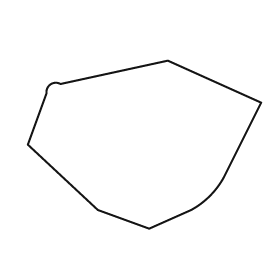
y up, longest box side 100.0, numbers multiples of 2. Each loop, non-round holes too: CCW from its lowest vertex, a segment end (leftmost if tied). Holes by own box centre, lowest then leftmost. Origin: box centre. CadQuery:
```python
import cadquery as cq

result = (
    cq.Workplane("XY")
    .moveTo(2.0, -36.0)
    .lineTo(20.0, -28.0)
    .threePointArc((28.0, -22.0), (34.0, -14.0))
    .lineTo(50.0, 18.0)
    .lineTo(10.0, 36.0)
    .lineTo(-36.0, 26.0)
    .threePointArc((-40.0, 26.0), (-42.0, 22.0))
    .lineTo(-50.0, 0.0)
    .lineTo(-20.0, -28.0)
    .close()
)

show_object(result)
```